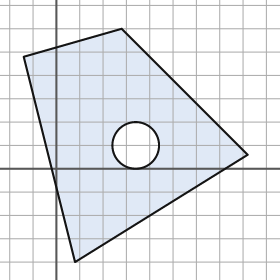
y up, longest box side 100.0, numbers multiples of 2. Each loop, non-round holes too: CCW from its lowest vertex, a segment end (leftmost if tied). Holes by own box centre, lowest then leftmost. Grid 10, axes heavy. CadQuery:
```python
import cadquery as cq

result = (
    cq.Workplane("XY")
    .moveTo(8.0, -40.0)
    .lineTo(82.0, 6.0)
    .lineTo(28.0, 60.0)
    .lineTo(-14.0, 48.0)
    .close()
    .moveTo(34.0, 10.0)
    .circle(10.0)
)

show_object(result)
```